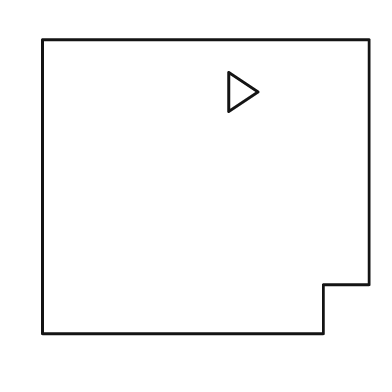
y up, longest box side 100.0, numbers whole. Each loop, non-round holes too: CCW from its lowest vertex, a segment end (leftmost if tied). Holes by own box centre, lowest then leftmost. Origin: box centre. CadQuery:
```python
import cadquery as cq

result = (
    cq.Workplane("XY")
    .moveTo(-50.0, -45.0)
    .lineTo(36.0, -45.0)
    .lineTo(36.0, -30.0)
    .lineTo(50.0, -30.0)
    .lineTo(50.0, 45.0)
    .lineTo(-50.0, 45.0)
    .close()
    .moveTo(7.0, 23.0)
    .lineTo(16.0, 29.0)
    .lineTo(7.0, 35.0)
    .close()
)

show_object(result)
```